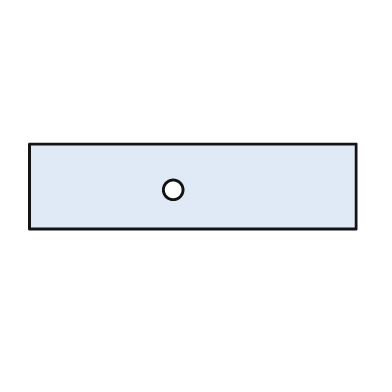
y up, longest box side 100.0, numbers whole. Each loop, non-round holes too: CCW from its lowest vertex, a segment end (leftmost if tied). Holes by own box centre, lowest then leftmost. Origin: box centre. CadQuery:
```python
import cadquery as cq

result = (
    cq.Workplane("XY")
    .moveTo(-50.0, -13.0)
    .lineTo(50.0, -13.0)
    .lineTo(50.0, 13.0)
    .lineTo(-50.0, 13.0)
    .close()
    .moveTo(-6.0, -1.0)
    .circle(3.0)
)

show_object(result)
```